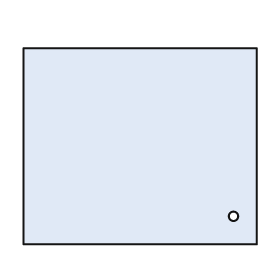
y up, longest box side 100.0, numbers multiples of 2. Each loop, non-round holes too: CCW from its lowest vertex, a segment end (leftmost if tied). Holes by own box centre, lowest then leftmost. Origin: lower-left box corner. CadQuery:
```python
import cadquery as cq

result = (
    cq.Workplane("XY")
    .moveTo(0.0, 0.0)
    .lineTo(100.0, 0.0)
    .lineTo(100.0, 84.0)
    .lineTo(0.0, 84.0)
    .close()
    .moveTo(90.0, 12.0)
    .circle(2.0)
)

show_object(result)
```